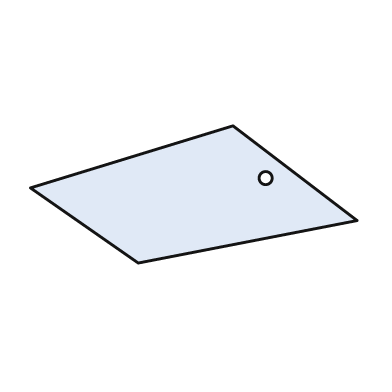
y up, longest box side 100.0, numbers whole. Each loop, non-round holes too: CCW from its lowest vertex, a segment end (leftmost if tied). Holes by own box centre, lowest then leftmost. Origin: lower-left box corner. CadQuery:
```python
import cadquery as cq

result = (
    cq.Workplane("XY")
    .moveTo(33.0, 0.0)
    .lineTo(100.0, 13.0)
    .lineTo(62.0, 42.0)
    .lineTo(0.0, 23.0)
    .close()
    .moveTo(72.0, 26.0)
    .circle(2.0)
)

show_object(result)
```